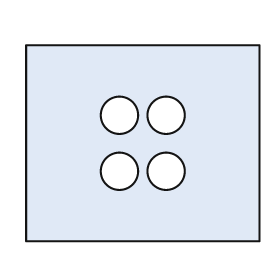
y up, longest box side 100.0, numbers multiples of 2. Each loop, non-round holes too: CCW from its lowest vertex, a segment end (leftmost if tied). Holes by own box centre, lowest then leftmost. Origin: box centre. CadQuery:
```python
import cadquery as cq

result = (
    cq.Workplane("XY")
    .moveTo(-50.0, -42.0)
    .lineTo(50.0, -42.0)
    .lineTo(50.0, 42.0)
    .lineTo(-50.0, 42.0)
    .close()
    .moveTo(-10.0, -12.0)
    .circle(8.0)
    .moveTo(10.0, -12.0)
    .circle(8.0)
    .moveTo(-10.0, 12.0)
    .circle(8.0)
    .moveTo(10.0, 12.0)
    .circle(8.0)
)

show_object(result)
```